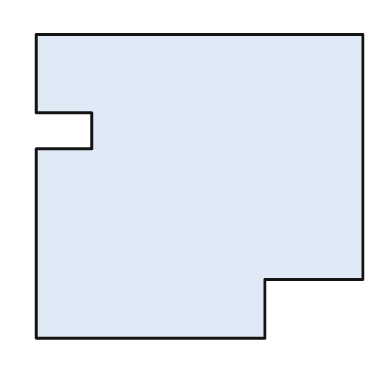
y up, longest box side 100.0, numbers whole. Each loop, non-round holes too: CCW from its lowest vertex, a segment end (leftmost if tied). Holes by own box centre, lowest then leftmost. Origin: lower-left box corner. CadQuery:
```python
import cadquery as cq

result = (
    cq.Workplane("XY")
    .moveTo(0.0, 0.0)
    .lineTo(70.0, 0.0)
    .lineTo(70.0, 18.0)
    .lineTo(100.0, 18.0)
    .lineTo(100.0, 93.0)
    .lineTo(0.0, 93.0)
    .lineTo(0.0, 69.0)
    .lineTo(17.0, 69.0)
    .lineTo(17.0, 58.0)
    .lineTo(0.0, 58.0)
    .close()
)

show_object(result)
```